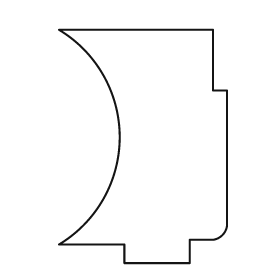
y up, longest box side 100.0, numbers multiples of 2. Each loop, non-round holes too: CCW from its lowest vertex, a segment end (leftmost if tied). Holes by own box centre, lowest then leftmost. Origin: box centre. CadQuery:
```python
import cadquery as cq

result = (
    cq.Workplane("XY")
    .moveTo(-8.0, -50.0)
    .lineTo(20.0, -50.0)
    .lineTo(20.0, -40.0)
    .lineTo(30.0, -40.0)
    .threePointArc((34.0, -38.0), (36.0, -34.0))
    .lineTo(36.0, 24.0)
    .lineTo(30.0, 24.0)
    .lineTo(30.0, 50.0)
    .lineTo(-36.0, 50.0)
    .threePointArc((-10.0, 4.0), (-36.0, -42.0))
    .lineTo(-8.0, -42.0)
    .close()
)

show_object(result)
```